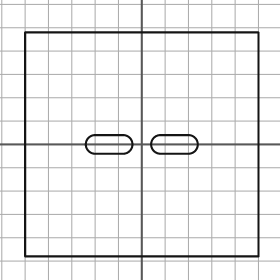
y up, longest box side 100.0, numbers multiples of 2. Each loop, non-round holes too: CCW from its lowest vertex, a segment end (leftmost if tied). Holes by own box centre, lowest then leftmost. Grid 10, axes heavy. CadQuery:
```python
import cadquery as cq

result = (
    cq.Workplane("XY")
    .moveTo(-50.0, -48.0)
    .lineTo(50.0, -48.0)
    .lineTo(50.0, 48.0)
    .lineTo(-50.0, 48.0)
    .close()
    .moveTo(-20.0, -4.0)
    .lineTo(-8.0, -4.0)
    .threePointArc((-4.0, 0.0), (-8.0, 4.0))
    .lineTo(-20.0, 4.0)
    .threePointArc((-24.0, 0.0), (-20.0, -4.0))
    .close()
    .moveTo(8.0, -4.0)
    .lineTo(20.0, -4.0)
    .threePointArc((24.0, 0.0), (20.0, 4.0))
    .lineTo(8.0, 4.0)
    .threePointArc((4.0, 0.0), (8.0, -4.0))
    .close()
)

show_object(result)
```